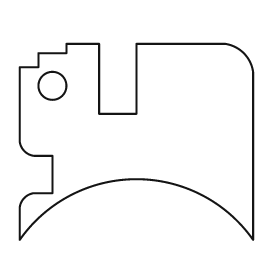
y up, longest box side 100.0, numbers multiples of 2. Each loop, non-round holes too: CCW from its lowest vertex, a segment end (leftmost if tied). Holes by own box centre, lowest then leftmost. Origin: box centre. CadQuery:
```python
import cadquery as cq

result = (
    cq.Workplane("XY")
    .moveTo(-50.0, -42.0)
    .threePointArc((0.0, -16.0), (50.0, -42.0))
    .lineTo(50.0, 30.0)
    .threePointArc((46.0, 38.0), (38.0, 42.0))
    .lineTo(0.0, 42.0)
    .lineTo(0.0, 12.0)
    .lineTo(-16.0, 12.0)
    .lineTo(-16.0, 42.0)
    .lineTo(-30.0, 42.0)
    .lineTo(-30.0, 38.0)
    .lineTo(-42.0, 38.0)
    .lineTo(-42.0, 32.0)
    .lineTo(-50.0, 32.0)
    .lineTo(-50.0, 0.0)
    .threePointArc((-48.0, -4.0), (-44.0, -6.0))
    .lineTo(-36.0, -6.0)
    .lineTo(-36.0, -22.0)
    .lineTo(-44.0, -22.0)
    .threePointArc((-48.0, -24.0), (-50.0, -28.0))
    .close()
    .moveTo(-36.0, 24.0)
    .circle(6.0)
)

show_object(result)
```